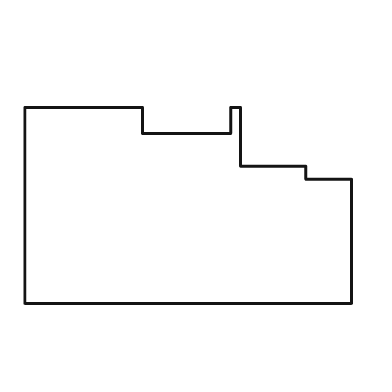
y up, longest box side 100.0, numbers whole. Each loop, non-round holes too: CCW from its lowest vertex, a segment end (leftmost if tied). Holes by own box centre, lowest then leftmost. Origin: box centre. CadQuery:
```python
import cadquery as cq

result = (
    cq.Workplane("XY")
    .moveTo(-50.0, -30.0)
    .lineTo(50.0, -30.0)
    .lineTo(50.0, 8.0)
    .lineTo(36.0, 8.0)
    .lineTo(36.0, 12.0)
    .lineTo(16.0, 12.0)
    .lineTo(16.0, 30.0)
    .lineTo(13.0, 30.0)
    .lineTo(13.0, 22.0)
    .lineTo(-14.0, 22.0)
    .lineTo(-14.0, 30.0)
    .lineTo(-50.0, 30.0)
    .close()
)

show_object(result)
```